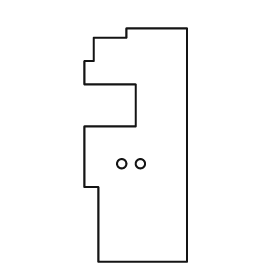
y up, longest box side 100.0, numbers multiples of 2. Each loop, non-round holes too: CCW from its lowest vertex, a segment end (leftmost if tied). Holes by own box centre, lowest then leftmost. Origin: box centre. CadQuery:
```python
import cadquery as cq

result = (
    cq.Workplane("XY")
    .moveTo(-16.0, -50.0)
    .lineTo(22.0, -50.0)
    .lineTo(22.0, 50.0)
    .lineTo(-4.0, 50.0)
    .lineTo(-4.0, 46.0)
    .lineTo(-18.0, 46.0)
    .lineTo(-18.0, 36.0)
    .lineTo(-22.0, 36.0)
    .lineTo(-22.0, 26.0)
    .lineTo(0.0, 26.0)
    .lineTo(0.0, 8.0)
    .lineTo(-22.0, 8.0)
    .lineTo(-22.0, -18.0)
    .lineTo(-16.0, -18.0)
    .close()
    .moveTo(-6.0, -8.0)
    .circle(2.0)
    .moveTo(2.0, -8.0)
    .circle(2.0)
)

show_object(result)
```